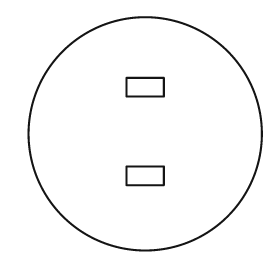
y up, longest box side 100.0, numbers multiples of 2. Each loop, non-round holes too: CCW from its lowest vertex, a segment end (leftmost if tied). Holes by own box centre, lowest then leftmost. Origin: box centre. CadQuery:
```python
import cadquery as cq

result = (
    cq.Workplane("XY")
    .moveTo(0.0, 0.0)
    .circle(50.0)
    .moveTo(-8.0, -22.0)
    .lineTo(8.0, -22.0)
    .lineTo(8.0, -14.0)
    .lineTo(-8.0, -14.0)
    .close()
    .moveTo(-8.0, 16.0)
    .lineTo(8.0, 16.0)
    .lineTo(8.0, 24.0)
    .lineTo(-8.0, 24.0)
    .close()
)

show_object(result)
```